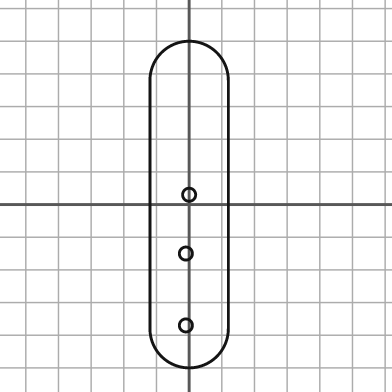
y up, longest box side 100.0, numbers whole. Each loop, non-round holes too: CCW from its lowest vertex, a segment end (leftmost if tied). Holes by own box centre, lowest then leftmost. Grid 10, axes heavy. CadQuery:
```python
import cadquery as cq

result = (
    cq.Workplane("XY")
    .moveTo(-12.0, -38.0)
    .threePointArc((0.0, -50.0), (12.0, -38.0))
    .lineTo(12.0, 38.0)
    .threePointArc((0.0, 50.0), (-12.0, 38.0))
    .close()
    .moveTo(-1.0, -37.0)
    .circle(2.0)
    .moveTo(-1.0, -15.0)
    .circle(2.0)
    .moveTo(0.0, 3.0)
    .circle(2.0)
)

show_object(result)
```